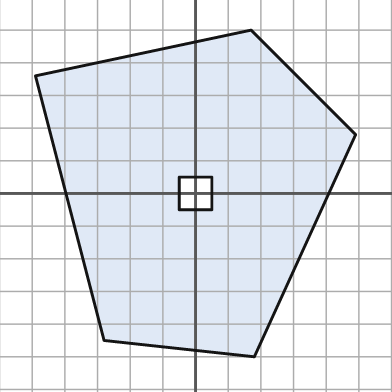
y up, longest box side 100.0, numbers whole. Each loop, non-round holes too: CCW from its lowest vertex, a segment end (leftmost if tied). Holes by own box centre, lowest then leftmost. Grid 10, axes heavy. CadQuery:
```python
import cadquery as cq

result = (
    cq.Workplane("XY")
    .moveTo(18.0, -50.0)
    .lineTo(49.0, 18.0)
    .lineTo(17.0, 50.0)
    .lineTo(-49.0, 36.0)
    .lineTo(-28.0, -45.0)
    .close()
    .moveTo(-5.0, -5.0)
    .lineTo(5.0, -5.0)
    .lineTo(5.0, 5.0)
    .lineTo(-5.0, 5.0)
    .close()
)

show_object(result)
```